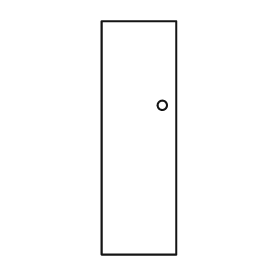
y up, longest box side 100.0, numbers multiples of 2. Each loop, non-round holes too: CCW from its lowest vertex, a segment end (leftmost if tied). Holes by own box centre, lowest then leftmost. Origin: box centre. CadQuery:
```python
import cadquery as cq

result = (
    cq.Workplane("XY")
    .moveTo(-16.0, -50.0)
    .lineTo(16.0, -50.0)
    .lineTo(16.0, 50.0)
    .lineTo(-16.0, 50.0)
    .close()
    .moveTo(10.0, 14.0)
    .circle(2.0)
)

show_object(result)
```